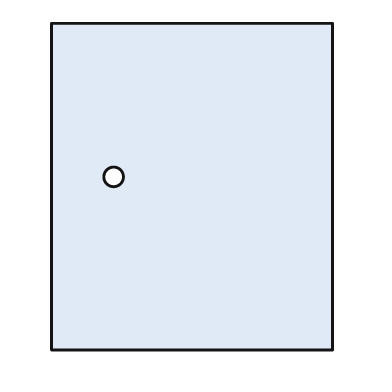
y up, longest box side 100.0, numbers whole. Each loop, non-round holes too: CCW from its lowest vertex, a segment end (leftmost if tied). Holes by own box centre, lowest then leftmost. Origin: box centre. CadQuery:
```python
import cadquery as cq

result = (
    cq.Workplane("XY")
    .moveTo(-43.0, -50.0)
    .lineTo(43.0, -50.0)
    .lineTo(43.0, 50.0)
    .lineTo(-43.0, 50.0)
    .close()
    .moveTo(-24.0, 3.0)
    .circle(3.0)
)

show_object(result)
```